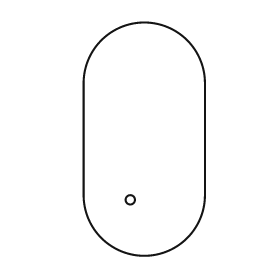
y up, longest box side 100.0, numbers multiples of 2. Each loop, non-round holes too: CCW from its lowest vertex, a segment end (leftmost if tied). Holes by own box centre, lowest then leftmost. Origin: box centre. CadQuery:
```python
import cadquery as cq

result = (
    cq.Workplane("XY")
    .moveTo(-26.0, -24.0)
    .threePointArc((0.0, -50.0), (26.0, -24.0))
    .lineTo(26.0, 24.0)
    .threePointArc((0.0, 50.0), (-26.0, 24.0))
    .close()
    .moveTo(-6.0, -26.0)
    .circle(2.0)
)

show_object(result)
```